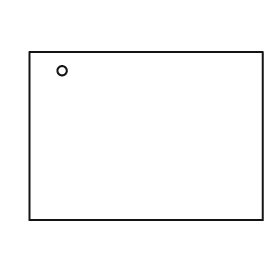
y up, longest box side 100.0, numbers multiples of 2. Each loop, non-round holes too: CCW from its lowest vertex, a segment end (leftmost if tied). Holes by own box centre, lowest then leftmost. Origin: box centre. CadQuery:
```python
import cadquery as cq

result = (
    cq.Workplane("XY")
    .moveTo(-50.0, -36.0)
    .lineTo(50.0, -36.0)
    .lineTo(50.0, 36.0)
    .lineTo(-50.0, 36.0)
    .close()
    .moveTo(-36.0, 28.0)
    .circle(2.0)
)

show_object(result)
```